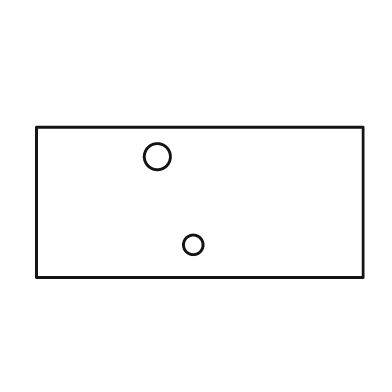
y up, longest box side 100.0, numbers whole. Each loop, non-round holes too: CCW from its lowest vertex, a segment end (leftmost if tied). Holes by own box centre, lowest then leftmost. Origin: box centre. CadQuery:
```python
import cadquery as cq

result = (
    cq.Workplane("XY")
    .moveTo(-50.0, -23.0)
    .lineTo(50.0, -23.0)
    .lineTo(50.0, 23.0)
    .lineTo(-50.0, 23.0)
    .close()
    .moveTo(-2.0, -13.0)
    .circle(3.0)
    .moveTo(-13.0, 14.0)
    .circle(4.0)
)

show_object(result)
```